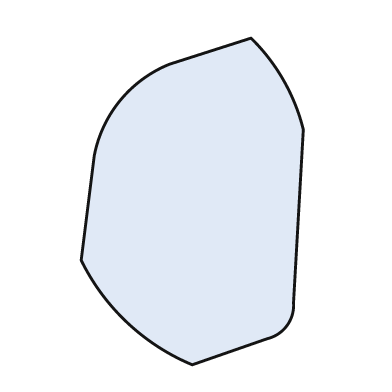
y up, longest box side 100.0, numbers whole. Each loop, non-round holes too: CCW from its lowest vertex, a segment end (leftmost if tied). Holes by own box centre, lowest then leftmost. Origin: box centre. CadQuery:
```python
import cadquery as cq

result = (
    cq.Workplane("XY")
    .moveTo(0.0, -50.0)
    .lineTo(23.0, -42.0)
    .threePointArc((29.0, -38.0), (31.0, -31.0))
    .lineTo(34.0, 22.0)
    .threePointArc((28.0, 37.0), (18.0, 50.0))
    .lineTo(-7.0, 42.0)
    .threePointArc((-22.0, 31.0), (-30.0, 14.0))
    .lineTo(-34.0, -18.0)
    .threePointArc((-20.0, -37.0), (0.0, -50.0))
    .close()
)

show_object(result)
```